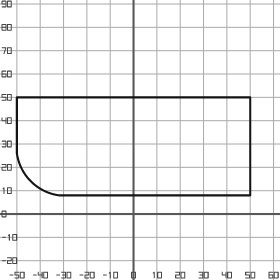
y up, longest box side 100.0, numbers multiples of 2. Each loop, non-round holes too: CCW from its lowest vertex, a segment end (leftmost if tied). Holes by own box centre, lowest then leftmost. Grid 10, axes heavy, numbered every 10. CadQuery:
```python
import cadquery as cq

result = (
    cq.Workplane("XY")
    .moveTo(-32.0, 8.0)
    .lineTo(50.0, 8.0)
    .lineTo(50.0, 50.0)
    .lineTo(-50.0, 50.0)
    .lineTo(-50.0, 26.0)
    .threePointArc((-44.0, 14.0), (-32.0, 8.0))
    .close()
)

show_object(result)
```